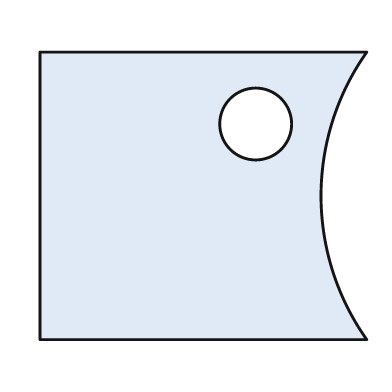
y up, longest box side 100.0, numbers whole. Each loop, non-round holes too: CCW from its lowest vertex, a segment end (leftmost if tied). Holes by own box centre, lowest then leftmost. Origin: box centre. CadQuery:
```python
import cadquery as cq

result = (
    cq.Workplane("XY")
    .moveTo(-50.0, -44.0)
    .lineTo(50.0, -44.0)
    .threePointArc((36.0, 0.0), (50.0, 44.0))
    .lineTo(-50.0, 44.0)
    .close()
    .moveTo(16.0, 22.0)
    .circle(11.0)
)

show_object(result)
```